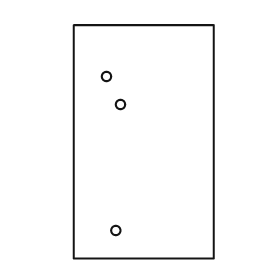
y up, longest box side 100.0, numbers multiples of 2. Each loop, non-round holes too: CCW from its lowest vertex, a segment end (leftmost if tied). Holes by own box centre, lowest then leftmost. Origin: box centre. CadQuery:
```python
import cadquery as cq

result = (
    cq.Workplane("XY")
    .moveTo(-30.0, -50.0)
    .lineTo(30.0, -50.0)
    .lineTo(30.0, 50.0)
    .lineTo(-30.0, 50.0)
    .close()
    .moveTo(-12.0, -38.0)
    .circle(2.0)
    .moveTo(-10.0, 16.0)
    .circle(2.0)
    .moveTo(-16.0, 28.0)
    .circle(2.0)
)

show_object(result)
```